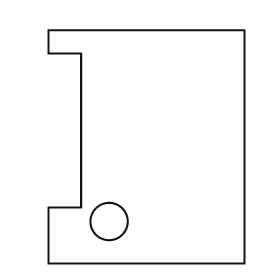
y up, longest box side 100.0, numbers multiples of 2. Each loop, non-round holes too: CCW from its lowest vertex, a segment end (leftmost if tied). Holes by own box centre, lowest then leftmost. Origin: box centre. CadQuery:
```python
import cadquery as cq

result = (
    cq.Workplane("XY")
    .moveTo(-42.0, -50.0)
    .lineTo(42.0, -50.0)
    .lineTo(42.0, 50.0)
    .lineTo(-42.0, 50.0)
    .lineTo(-42.0, 40.0)
    .lineTo(-28.0, 40.0)
    .lineTo(-28.0, -26.0)
    .lineTo(-42.0, -26.0)
    .close()
    .moveTo(-16.0, -32.0)
    .circle(8.0)
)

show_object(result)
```